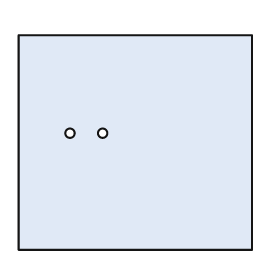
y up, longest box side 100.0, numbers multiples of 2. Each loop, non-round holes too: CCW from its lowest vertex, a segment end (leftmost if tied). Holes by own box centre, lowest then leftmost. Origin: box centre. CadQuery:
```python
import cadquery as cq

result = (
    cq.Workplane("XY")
    .moveTo(-50.0, -46.0)
    .lineTo(50.0, -46.0)
    .lineTo(50.0, 46.0)
    .lineTo(-50.0, 46.0)
    .close()
    .moveTo(-28.0, 4.0)
    .circle(2.0)
    .moveTo(-14.0, 4.0)
    .circle(2.0)
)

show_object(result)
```